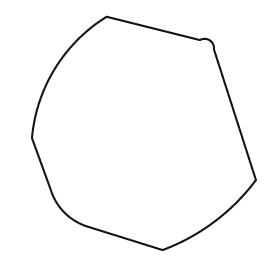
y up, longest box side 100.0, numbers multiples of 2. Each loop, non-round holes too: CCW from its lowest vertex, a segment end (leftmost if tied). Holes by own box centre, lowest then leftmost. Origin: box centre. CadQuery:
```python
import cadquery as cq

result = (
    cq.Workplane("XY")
    .moveTo(8.0, -50.0)
    .threePointArc((30.0, -38.0), (48.0, -20.0))
    .lineTo(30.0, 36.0)
    .threePointArc((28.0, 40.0), (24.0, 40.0))
    .lineTo(-16.0, 50.0)
    .threePointArc((-38.0, 28.0), (-48.0, -2.0))
    .lineTo(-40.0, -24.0)
    .threePointArc((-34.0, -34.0), (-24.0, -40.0))
    .close()
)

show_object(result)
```